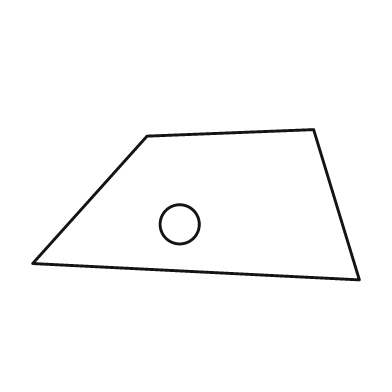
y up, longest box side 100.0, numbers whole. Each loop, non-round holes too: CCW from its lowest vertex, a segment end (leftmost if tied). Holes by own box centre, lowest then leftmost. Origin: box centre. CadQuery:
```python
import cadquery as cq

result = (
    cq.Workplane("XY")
    .moveTo(50.0, -23.0)
    .lineTo(36.0, 23.0)
    .lineTo(-15.0, 21.0)
    .lineTo(-50.0, -18.0)
    .close()
    .moveTo(-5.0, -6.0)
    .circle(6.0)
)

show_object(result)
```